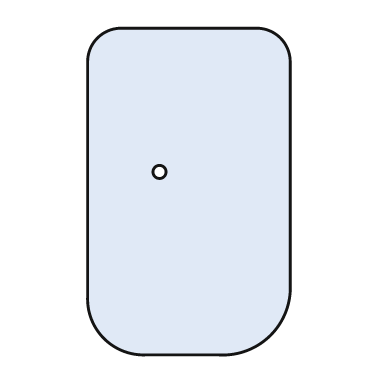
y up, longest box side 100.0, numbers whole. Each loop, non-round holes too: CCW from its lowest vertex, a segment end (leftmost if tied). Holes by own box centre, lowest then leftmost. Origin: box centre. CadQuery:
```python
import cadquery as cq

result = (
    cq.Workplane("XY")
    .moveTo(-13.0, -50.0)
    .lineTo(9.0, -50.0)
    .threePointArc((25.0, -44.0), (31.0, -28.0))
    .lineTo(31.0, 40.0)
    .threePointArc((28.0, 47.0), (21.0, 50.0))
    .lineTo(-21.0, 50.0)
    .threePointArc((-28.0, 47.0), (-31.0, 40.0))
    .lineTo(-31.0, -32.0)
    .threePointArc((-26.0, -45.0), (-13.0, -50.0))
    .close()
    .moveTo(-9.0, 6.0)
    .circle(2.0)
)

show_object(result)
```